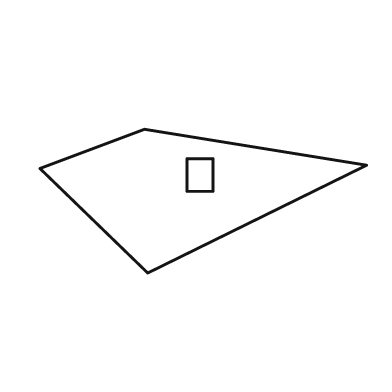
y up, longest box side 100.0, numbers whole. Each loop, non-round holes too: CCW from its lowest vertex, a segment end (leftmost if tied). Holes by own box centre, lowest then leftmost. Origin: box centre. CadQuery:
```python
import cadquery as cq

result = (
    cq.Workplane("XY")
    .moveTo(-17.0, -22.0)
    .lineTo(50.0, 11.0)
    .lineTo(-18.0, 22.0)
    .lineTo(-50.0, 10.0)
    .close()
    .moveTo(-5.0, 3.0)
    .lineTo(3.0, 3.0)
    .lineTo(3.0, 13.0)
    .lineTo(-5.0, 13.0)
    .close()
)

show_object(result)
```